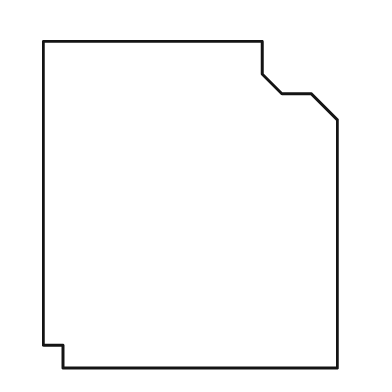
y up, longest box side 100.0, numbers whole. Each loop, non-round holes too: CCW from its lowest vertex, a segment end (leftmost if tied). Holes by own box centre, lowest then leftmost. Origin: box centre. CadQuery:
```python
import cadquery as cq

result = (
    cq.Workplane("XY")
    .moveTo(-39.0, -50.0)
    .lineTo(45.0, -50.0)
    .lineTo(45.0, 26.0)
    .lineTo(37.0, 34.0)
    .lineTo(28.0, 34.0)
    .lineTo(22.0, 40.0)
    .lineTo(22.0, 50.0)
    .lineTo(-45.0, 50.0)
    .lineTo(-45.0, -43.0)
    .lineTo(-39.0, -43.0)
    .close()
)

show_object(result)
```